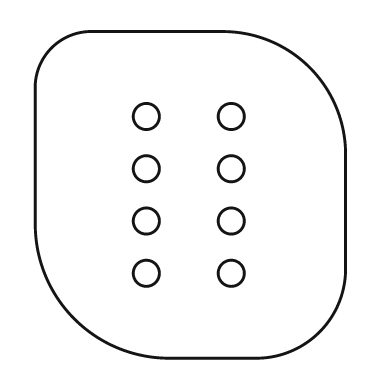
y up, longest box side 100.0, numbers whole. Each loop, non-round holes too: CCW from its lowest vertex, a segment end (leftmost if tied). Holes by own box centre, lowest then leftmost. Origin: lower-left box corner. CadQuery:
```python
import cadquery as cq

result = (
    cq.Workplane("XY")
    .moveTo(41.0, 0.0)
    .lineTo(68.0, 0.0)
    .threePointArc((87.0, 8.0), (95.0, 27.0))
    .lineTo(95.0, 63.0)
    .threePointArc((84.0, 89.0), (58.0, 100.0))
    .lineTo(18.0, 100.0)
    .threePointArc((5.0, 95.0), (0.0, 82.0))
    .lineTo(0.0, 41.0)
    .threePointArc((12.0, 12.0), (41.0, 0.0))
    .close()
    .moveTo(34.0, 26.0)
    .circle(4.0)
    .moveTo(60.0, 26.0)
    .circle(4.0)
    .moveTo(34.0, 42.0)
    .circle(4.0)
    .moveTo(60.0, 42.0)
    .circle(4.0)
    .moveTo(34.0, 58.0)
    .circle(4.0)
    .moveTo(60.0, 58.0)
    .circle(4.0)
    .moveTo(34.0, 74.0)
    .circle(4.0)
    .moveTo(60.0, 74.0)
    .circle(4.0)
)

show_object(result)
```